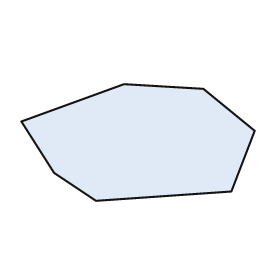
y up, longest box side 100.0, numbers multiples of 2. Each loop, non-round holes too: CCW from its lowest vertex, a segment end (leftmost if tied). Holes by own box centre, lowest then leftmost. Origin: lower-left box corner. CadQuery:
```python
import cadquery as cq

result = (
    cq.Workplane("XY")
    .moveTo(32.0, 0.0)
    .lineTo(90.0, 4.0)
    .lineTo(100.0, 30.0)
    .lineTo(78.0, 48.0)
    .lineTo(44.0, 50.0)
    .lineTo(0.0, 34.0)
    .lineTo(14.0, 12.0)
    .close()
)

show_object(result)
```